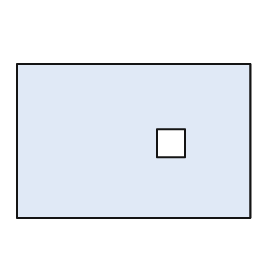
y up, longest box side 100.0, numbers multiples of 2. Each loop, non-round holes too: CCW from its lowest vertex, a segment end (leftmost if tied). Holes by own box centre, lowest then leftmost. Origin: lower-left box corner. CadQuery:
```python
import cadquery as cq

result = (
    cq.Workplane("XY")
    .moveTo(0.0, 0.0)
    .lineTo(100.0, 0.0)
    .lineTo(100.0, 66.0)
    .lineTo(0.0, 66.0)
    .close()
    .moveTo(60.0, 26.0)
    .lineTo(72.0, 26.0)
    .lineTo(72.0, 38.0)
    .lineTo(60.0, 38.0)
    .close()
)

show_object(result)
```